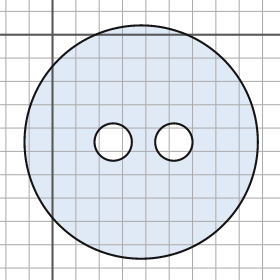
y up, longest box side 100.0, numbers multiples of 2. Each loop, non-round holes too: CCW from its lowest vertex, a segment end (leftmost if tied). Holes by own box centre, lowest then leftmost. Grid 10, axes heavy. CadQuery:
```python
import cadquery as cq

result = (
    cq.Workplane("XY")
    .moveTo(38.0, -46.0)
    .circle(50.0)
    .moveTo(26.0, -46.0)
    .circle(8.0)
    .moveTo(52.0, -46.0)
    .circle(8.0)
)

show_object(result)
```